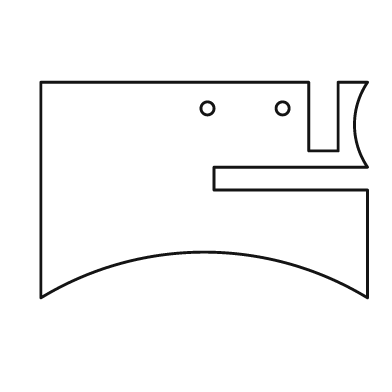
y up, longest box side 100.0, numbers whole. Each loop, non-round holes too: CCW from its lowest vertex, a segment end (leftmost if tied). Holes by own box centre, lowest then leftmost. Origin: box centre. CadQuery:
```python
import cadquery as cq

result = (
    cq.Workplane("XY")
    .moveTo(-50.0, -33.0)
    .threePointArc((0.0, -19.0), (50.0, -33.0))
    .lineTo(50.0, 0.0)
    .lineTo(3.0, 0.0)
    .lineTo(3.0, 7.0)
    .lineTo(50.0, 7.0)
    .threePointArc((46.0, 20.0), (50.0, 33.0))
    .lineTo(41.0, 33.0)
    .lineTo(41.0, 12.0)
    .lineTo(32.0, 12.0)
    .lineTo(32.0, 33.0)
    .lineTo(-50.0, 33.0)
    .close()
    .moveTo(1.0, 25.0)
    .circle(2.0)
    .moveTo(24.0, 25.0)
    .circle(2.0)
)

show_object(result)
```